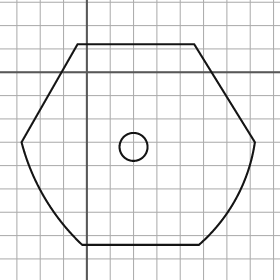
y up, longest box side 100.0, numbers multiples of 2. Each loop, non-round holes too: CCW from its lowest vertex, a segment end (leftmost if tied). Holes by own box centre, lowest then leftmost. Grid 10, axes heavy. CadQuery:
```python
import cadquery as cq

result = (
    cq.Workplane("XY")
    .moveTo(-2.0, -74.0)
    .lineTo(48.0, -74.0)
    .threePointArc((64.0, -54.0), (72.0, -30.0))
    .lineTo(46.0, 12.0)
    .lineTo(-4.0, 12.0)
    .lineTo(-28.0, -30.0)
    .threePointArc((-18.0, -54.0), (-2.0, -74.0))
    .close()
    .moveTo(20.0, -32.0)
    .circle(6.0)
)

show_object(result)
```